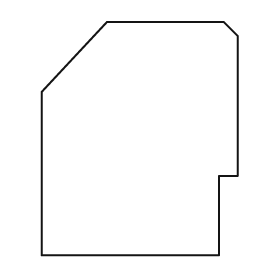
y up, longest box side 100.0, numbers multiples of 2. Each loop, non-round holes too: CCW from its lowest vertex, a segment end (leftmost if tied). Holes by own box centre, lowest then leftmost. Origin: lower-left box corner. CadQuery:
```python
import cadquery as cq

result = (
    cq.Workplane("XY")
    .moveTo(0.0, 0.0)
    .lineTo(76.0, 0.0)
    .lineTo(76.0, 34.0)
    .lineTo(84.0, 34.0)
    .lineTo(84.0, 94.0)
    .lineTo(78.0, 100.0)
    .lineTo(28.0, 100.0)
    .lineTo(0.0, 70.0)
    .close()
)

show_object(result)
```